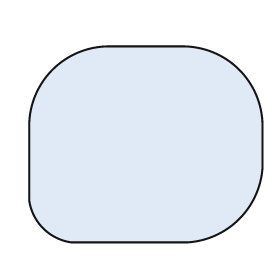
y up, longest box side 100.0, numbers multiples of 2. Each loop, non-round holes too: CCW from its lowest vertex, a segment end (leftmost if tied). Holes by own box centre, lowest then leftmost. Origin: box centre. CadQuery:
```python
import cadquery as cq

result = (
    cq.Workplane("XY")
    .moveTo(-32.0, -42.0)
    .lineTo(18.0, -42.0)
    .threePointArc((40.0, -32.0), (50.0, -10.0))
    .lineTo(50.0, 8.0)
    .threePointArc((40.0, 32.0), (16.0, 42.0))
    .lineTo(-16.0, 42.0)
    .threePointArc((-40.0, 32.0), (-50.0, 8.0))
    .lineTo(-50.0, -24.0)
    .threePointArc((-44.0, -36.0), (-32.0, -42.0))
    .close()
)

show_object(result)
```